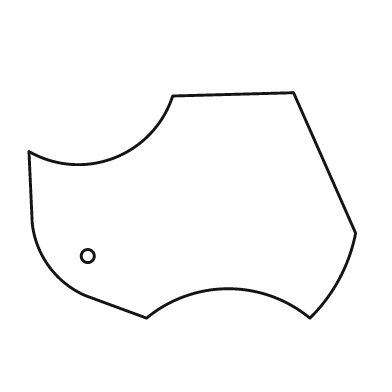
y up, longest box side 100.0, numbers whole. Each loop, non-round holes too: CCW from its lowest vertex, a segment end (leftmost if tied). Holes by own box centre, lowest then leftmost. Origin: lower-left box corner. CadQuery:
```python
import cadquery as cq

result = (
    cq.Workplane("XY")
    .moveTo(36.0, 0.0)
    .threePointArc((61.0, 9.0), (86.0, 0.0))
    .threePointArc((95.0, 12.0), (100.0, 26.0))
    .lineTo(81.0, 69.0)
    .lineTo(44.0, 68.0)
    .threePointArc((26.0, 49.0), (0.0, 51.0))
    .lineTo(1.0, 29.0)
    .threePointArc((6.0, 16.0), (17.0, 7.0))
    .close()
    .moveTo(18.0, 19.0)
    .circle(2.0)
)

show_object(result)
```